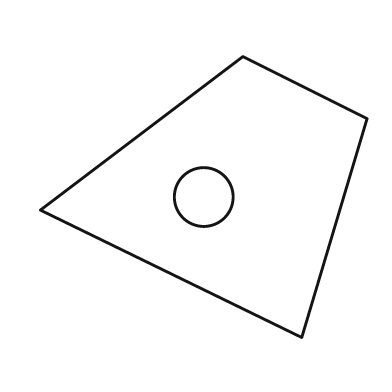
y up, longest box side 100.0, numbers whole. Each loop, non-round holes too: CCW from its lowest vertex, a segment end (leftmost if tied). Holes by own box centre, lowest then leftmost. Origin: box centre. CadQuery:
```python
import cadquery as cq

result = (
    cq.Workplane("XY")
    .moveTo(30.0, -43.0)
    .lineTo(50.0, 24.0)
    .lineTo(12.0, 43.0)
    .lineTo(-50.0, -4.0)
    .close()
    .moveTo(0.0, 0.0)
    .circle(9.0)
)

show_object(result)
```